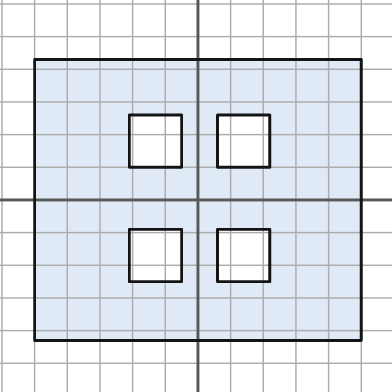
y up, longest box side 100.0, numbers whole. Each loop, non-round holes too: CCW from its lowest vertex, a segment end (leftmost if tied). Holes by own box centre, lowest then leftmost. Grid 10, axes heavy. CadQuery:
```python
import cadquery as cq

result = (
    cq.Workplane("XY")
    .moveTo(-50.0, -43.0)
    .lineTo(50.0, -43.0)
    .lineTo(50.0, 43.0)
    .lineTo(-50.0, 43.0)
    .close()
    .moveTo(-21.0, -25.0)
    .lineTo(-5.0, -25.0)
    .lineTo(-5.0, -9.0)
    .lineTo(-21.0, -9.0)
    .close()
    .moveTo(6.0, -25.0)
    .lineTo(22.0, -25.0)
    .lineTo(22.0, -9.0)
    .lineTo(6.0, -9.0)
    .close()
    .moveTo(-21.0, 10.0)
    .lineTo(-5.0, 10.0)
    .lineTo(-5.0, 26.0)
    .lineTo(-21.0, 26.0)
    .close()
    .moveTo(6.0, 10.0)
    .lineTo(22.0, 10.0)
    .lineTo(22.0, 26.0)
    .lineTo(6.0, 26.0)
    .close()
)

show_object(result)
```